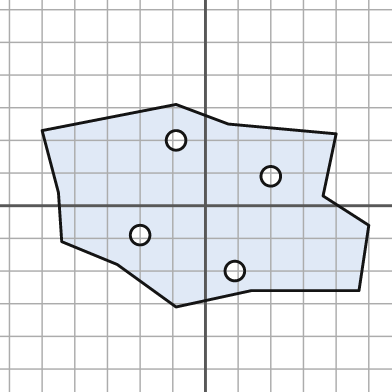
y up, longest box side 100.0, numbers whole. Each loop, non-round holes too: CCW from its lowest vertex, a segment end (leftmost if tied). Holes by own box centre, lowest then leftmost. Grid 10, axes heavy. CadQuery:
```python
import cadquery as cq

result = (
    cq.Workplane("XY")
    .moveTo(-9.0, -31.0)
    .lineTo(14.0, -26.0)
    .lineTo(47.0, -26.0)
    .lineTo(50.0, -6.0)
    .lineTo(36.0, 3.0)
    .lineTo(40.0, 22.0)
    .lineTo(7.0, 25.0)
    .lineTo(-9.0, 31.0)
    .lineTo(-50.0, 23.0)
    .lineTo(-45.0, 4.0)
    .lineTo(-44.0, -11.0)
    .lineTo(-27.0, -18.0)
    .close()
    .moveTo(9.0, -20.0)
    .circle(3.0)
    .moveTo(-20.0, -9.0)
    .circle(3.0)
    .moveTo(20.0, 9.0)
    .circle(3.0)
    .moveTo(-9.0, 20.0)
    .circle(3.0)
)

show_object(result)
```